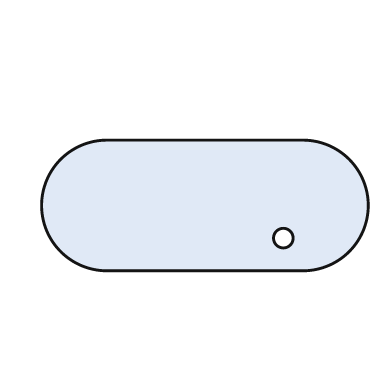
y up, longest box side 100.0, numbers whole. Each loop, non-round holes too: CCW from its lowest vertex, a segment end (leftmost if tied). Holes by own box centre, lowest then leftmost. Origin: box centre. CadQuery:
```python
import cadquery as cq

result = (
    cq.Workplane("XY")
    .moveTo(-30.0, -20.0)
    .lineTo(30.0, -20.0)
    .threePointArc((50.0, 0.0), (30.0, 20.0))
    .lineTo(-30.0, 20.0)
    .threePointArc((-50.0, 0.0), (-30.0, -20.0))
    .close()
    .moveTo(24.0, -10.0)
    .circle(3.0)
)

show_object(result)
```